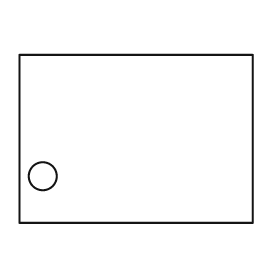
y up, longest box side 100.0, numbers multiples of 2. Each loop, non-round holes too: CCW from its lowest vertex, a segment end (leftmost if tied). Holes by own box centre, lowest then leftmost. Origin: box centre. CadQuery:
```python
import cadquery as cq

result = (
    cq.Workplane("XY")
    .moveTo(-50.0, -36.0)
    .lineTo(50.0, -36.0)
    .lineTo(50.0, 36.0)
    .lineTo(-50.0, 36.0)
    .close()
    .moveTo(-40.0, -16.0)
    .circle(6.0)
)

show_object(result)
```